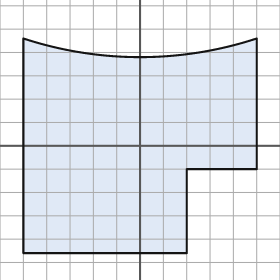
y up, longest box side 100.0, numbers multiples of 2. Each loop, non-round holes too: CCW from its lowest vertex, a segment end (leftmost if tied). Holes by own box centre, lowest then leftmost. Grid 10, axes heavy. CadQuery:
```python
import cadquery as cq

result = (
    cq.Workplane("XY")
    .moveTo(-50.0, -46.0)
    .lineTo(20.0, -46.0)
    .lineTo(20.0, -10.0)
    .lineTo(50.0, -10.0)
    .lineTo(50.0, 46.0)
    .threePointArc((0.0, 38.0), (-50.0, 46.0))
    .close()
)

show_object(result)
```